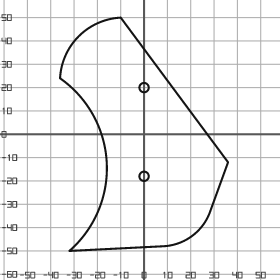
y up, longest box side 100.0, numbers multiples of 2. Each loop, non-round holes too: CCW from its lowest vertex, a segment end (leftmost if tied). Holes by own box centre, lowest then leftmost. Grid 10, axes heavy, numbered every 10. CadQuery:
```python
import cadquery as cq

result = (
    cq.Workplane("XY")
    .moveTo(-32.0, -50.0)
    .lineTo(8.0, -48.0)
    .threePointArc((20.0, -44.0), (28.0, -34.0))
    .lineTo(36.0, -12.0)
    .lineTo(-10.0, 50.0)
    .threePointArc((-28.0, 42.0), (-36.0, 24.0))
    .threePointArc((-16.0, -12.0), (-32.0, -50.0))
    .close()
    .moveTo(0.0, -18.0)
    .circle(2.0)
    .moveTo(0.0, 20.0)
    .circle(2.0)
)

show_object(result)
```